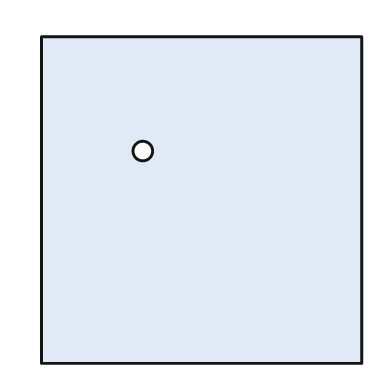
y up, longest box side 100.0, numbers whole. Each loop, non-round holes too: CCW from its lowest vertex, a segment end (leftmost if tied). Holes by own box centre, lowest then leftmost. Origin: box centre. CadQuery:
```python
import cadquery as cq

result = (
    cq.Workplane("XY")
    .moveTo(-49.0, -50.0)
    .lineTo(49.0, -50.0)
    .lineTo(49.0, 50.0)
    .lineTo(-49.0, 50.0)
    .close()
    .moveTo(-18.0, 15.0)
    .circle(3.0)
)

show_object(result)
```